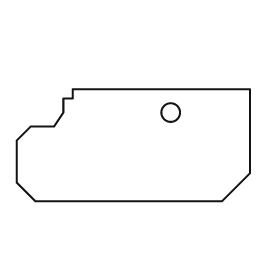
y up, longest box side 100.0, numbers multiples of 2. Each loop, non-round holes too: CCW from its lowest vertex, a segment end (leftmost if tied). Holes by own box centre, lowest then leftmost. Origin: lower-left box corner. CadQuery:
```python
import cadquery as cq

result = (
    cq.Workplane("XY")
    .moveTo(8.0, 0.0)
    .lineTo(88.0, 0.0)
    .lineTo(100.0, 12.0)
    .lineTo(100.0, 48.0)
    .lineTo(24.0, 48.0)
    .lineTo(24.0, 44.0)
    .lineTo(20.0, 44.0)
    .lineTo(20.0, 38.0)
    .lineTo(16.0, 32.0)
    .lineTo(6.0, 32.0)
    .lineTo(0.0, 26.0)
    .lineTo(0.0, 8.0)
    .close()
    .moveTo(66.0, 38.0)
    .circle(4.0)
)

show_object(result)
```